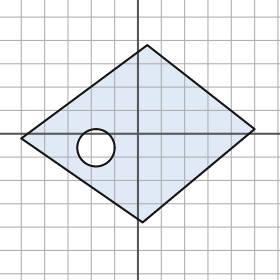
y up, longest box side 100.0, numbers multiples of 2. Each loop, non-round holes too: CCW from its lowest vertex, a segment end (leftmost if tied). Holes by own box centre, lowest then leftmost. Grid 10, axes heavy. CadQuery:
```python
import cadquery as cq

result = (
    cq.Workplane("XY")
    .moveTo(2.0, -38.0)
    .lineTo(50.0, 2.0)
    .lineTo(4.0, 38.0)
    .lineTo(-50.0, -2.0)
    .close()
    .moveTo(-18.0, -6.0)
    .circle(8.0)
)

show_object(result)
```